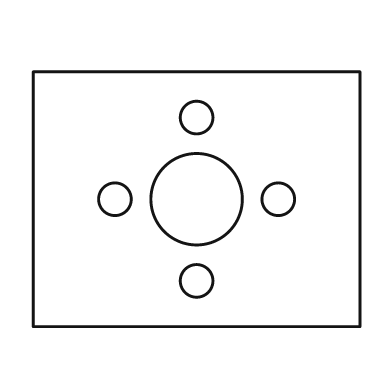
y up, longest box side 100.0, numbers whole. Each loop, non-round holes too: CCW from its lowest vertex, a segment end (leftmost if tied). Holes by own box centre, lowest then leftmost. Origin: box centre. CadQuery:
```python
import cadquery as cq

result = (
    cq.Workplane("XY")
    .moveTo(-50.0, -39.0)
    .lineTo(50.0, -39.0)
    .lineTo(50.0, 39.0)
    .lineTo(-50.0, 39.0)
    .close()
    .moveTo(0.0, -25.0)
    .circle(5.0)
    .moveTo(-25.0, 0.0)
    .circle(5.0)
    .moveTo(0.0, 0.0)
    .circle(14.0)
    .moveTo(25.0, 0.0)
    .circle(5.0)
    .moveTo(0.0, 25.0)
    .circle(5.0)
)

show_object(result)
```